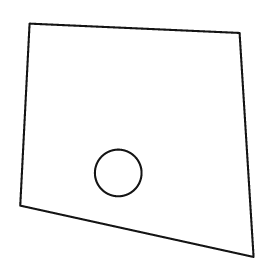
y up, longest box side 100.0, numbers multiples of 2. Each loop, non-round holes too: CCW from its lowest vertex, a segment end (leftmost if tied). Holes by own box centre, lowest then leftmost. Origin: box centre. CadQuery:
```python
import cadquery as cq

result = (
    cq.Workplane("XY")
    .moveTo(50.0, -50.0)
    .lineTo(44.0, 46.0)
    .lineTo(-46.0, 50.0)
    .lineTo(-50.0, -28.0)
    .close()
    .moveTo(-8.0, -14.0)
    .circle(10.0)
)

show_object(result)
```